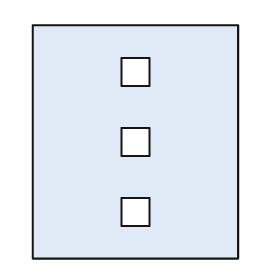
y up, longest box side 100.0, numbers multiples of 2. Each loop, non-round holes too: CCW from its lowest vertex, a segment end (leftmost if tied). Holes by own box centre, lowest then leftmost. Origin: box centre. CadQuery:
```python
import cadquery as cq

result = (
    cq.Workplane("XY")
    .moveTo(-44.0, -50.0)
    .lineTo(44.0, -50.0)
    .lineTo(44.0, 50.0)
    .lineTo(-44.0, 50.0)
    .close()
    .moveTo(-6.0, -36.0)
    .lineTo(6.0, -36.0)
    .lineTo(6.0, -24.0)
    .lineTo(-6.0, -24.0)
    .close()
    .moveTo(-6.0, -6.0)
    .lineTo(6.0, -6.0)
    .lineTo(6.0, 6.0)
    .lineTo(-6.0, 6.0)
    .close()
    .moveTo(-6.0, 24.0)
    .lineTo(6.0, 24.0)
    .lineTo(6.0, 36.0)
    .lineTo(-6.0, 36.0)
    .close()
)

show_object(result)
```